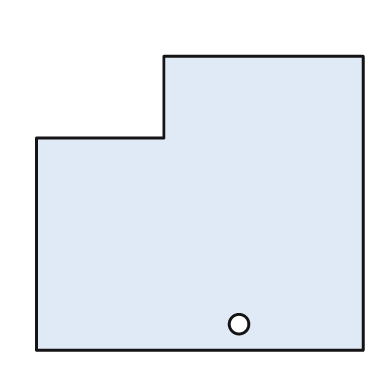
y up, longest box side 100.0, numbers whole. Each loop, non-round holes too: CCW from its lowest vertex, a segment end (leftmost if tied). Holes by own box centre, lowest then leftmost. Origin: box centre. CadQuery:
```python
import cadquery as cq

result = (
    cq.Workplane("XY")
    .moveTo(-50.0, -45.0)
    .lineTo(50.0, -45.0)
    .lineTo(50.0, 45.0)
    .lineTo(-11.0, 45.0)
    .lineTo(-11.0, 20.0)
    .lineTo(-50.0, 20.0)
    .close()
    .moveTo(12.0, -37.0)
    .circle(3.0)
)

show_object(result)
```